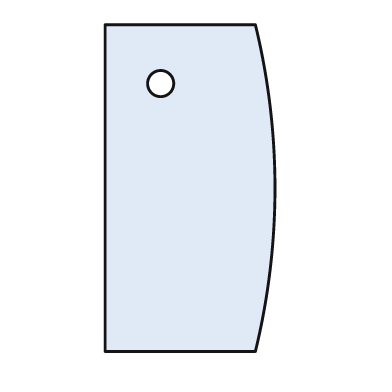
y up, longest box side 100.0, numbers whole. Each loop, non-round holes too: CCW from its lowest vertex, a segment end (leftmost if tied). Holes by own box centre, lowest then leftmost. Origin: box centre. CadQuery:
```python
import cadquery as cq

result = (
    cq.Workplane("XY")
    .moveTo(-26.0, -50.0)
    .lineTo(20.0, -50.0)
    .threePointArc((26.0, 0.0), (20.0, 50.0))
    .lineTo(-26.0, 50.0)
    .close()
    .moveTo(-9.0, 32.0)
    .circle(4.0)
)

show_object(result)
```